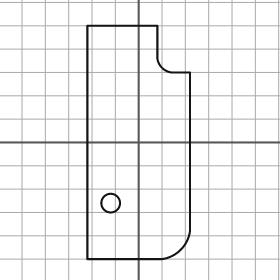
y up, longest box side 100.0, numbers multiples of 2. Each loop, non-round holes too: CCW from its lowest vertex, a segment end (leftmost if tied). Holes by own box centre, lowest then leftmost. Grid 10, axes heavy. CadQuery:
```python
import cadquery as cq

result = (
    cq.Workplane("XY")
    .moveTo(-22.0, -50.0)
    .lineTo(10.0, -50.0)
    .threePointArc((18.0, -46.0), (22.0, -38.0))
    .lineTo(22.0, 30.0)
    .lineTo(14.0, 30.0)
    .threePointArc((10.0, 32.0), (8.0, 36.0))
    .lineTo(8.0, 50.0)
    .lineTo(-22.0, 50.0)
    .close()
    .moveTo(-12.0, -26.0)
    .circle(4.0)
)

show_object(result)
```